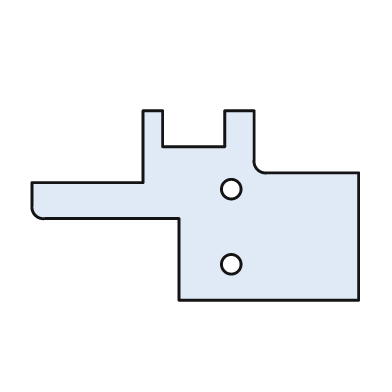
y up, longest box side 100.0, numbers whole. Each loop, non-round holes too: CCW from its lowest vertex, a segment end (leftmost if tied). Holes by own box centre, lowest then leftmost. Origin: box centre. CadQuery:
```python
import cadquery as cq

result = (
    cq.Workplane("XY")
    .moveTo(-5.0, -29.0)
    .lineTo(50.0, -29.0)
    .lineTo(50.0, 10.0)
    .lineTo(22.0, 10.0)
    .threePointArc((19.0, 11.0), (18.0, 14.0))
    .lineTo(18.0, 29.0)
    .lineTo(9.0, 29.0)
    .lineTo(9.0, 18.0)
    .lineTo(-10.0, 18.0)
    .lineTo(-10.0, 29.0)
    .lineTo(-16.0, 29.0)
    .lineTo(-16.0, 7.0)
    .lineTo(-50.0, 7.0)
    .lineTo(-50.0, 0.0)
    .threePointArc((-49.0, -3.0), (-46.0, -4.0))
    .lineTo(-5.0, -4.0)
    .close()
    .moveTo(11.0, -18.0)
    .circle(3.0)
    .moveTo(11.0, 5.0)
    .circle(3.0)
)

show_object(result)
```